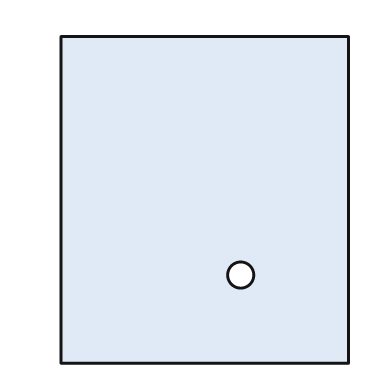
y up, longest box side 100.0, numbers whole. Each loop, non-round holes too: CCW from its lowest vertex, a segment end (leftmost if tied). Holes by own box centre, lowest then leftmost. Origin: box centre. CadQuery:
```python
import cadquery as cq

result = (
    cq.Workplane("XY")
    .moveTo(-44.0, -50.0)
    .lineTo(44.0, -50.0)
    .lineTo(44.0, 50.0)
    .lineTo(-44.0, 50.0)
    .close()
    .moveTo(11.0, -23.0)
    .circle(4.0)
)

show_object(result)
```